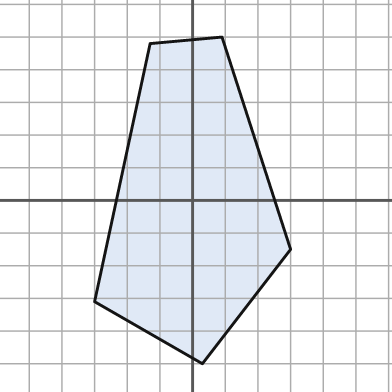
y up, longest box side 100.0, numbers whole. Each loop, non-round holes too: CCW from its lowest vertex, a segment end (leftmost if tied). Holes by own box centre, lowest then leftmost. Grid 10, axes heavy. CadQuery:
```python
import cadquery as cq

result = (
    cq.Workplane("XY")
    .moveTo(3.0, -50.0)
    .lineTo(30.0, -15.0)
    .lineTo(9.0, 50.0)
    .lineTo(-13.0, 48.0)
    .lineTo(-30.0, -31.0)
    .close()
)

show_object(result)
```